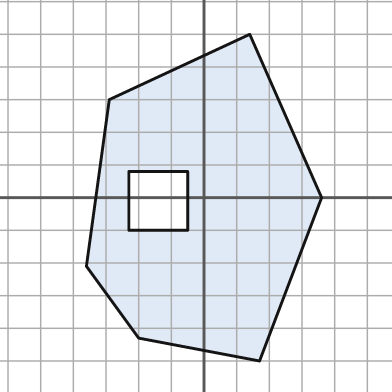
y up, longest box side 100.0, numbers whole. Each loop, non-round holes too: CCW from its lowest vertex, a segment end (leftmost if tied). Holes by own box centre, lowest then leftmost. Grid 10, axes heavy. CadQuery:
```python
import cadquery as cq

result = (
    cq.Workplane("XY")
    .moveTo(17.0, -50.0)
    .lineTo(36.0, 0.0)
    .lineTo(14.0, 50.0)
    .lineTo(-29.0, 30.0)
    .lineTo(-36.0, -21.0)
    .lineTo(-20.0, -43.0)
    .close()
    .moveTo(-23.0, -10.0)
    .lineTo(-5.0, -10.0)
    .lineTo(-5.0, 8.0)
    .lineTo(-23.0, 8.0)
    .close()
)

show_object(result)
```